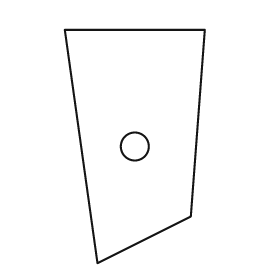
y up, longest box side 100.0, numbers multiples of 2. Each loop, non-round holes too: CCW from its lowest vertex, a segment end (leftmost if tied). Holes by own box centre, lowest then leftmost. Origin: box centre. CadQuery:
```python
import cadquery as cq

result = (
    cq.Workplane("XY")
    .moveTo(-16.0, -50.0)
    .lineTo(24.0, -30.0)
    .lineTo(30.0, 50.0)
    .lineTo(-30.0, 50.0)
    .close()
    .moveTo(0.0, 0.0)
    .circle(6.0)
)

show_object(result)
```